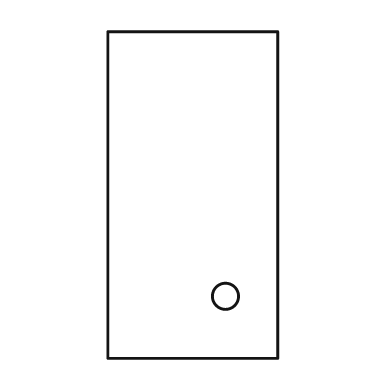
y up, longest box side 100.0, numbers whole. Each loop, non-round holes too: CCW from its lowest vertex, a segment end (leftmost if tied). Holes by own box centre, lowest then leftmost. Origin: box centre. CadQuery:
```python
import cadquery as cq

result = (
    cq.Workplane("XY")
    .moveTo(-26.0, -50.0)
    .lineTo(26.0, -50.0)
    .lineTo(26.0, 50.0)
    .lineTo(-26.0, 50.0)
    .close()
    .moveTo(10.0, -31.0)
    .circle(4.0)
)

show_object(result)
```